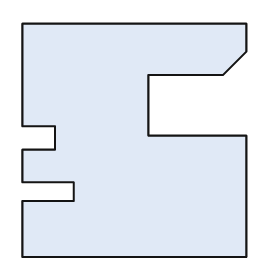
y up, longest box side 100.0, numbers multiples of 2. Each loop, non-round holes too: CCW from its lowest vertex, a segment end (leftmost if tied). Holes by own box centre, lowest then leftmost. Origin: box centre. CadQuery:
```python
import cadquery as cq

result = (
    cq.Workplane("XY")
    .moveTo(-48.0, -50.0)
    .lineTo(48.0, -50.0)
    .lineTo(48.0, 2.0)
    .lineTo(6.0, 2.0)
    .lineTo(6.0, 28.0)
    .lineTo(38.0, 28.0)
    .lineTo(48.0, 38.0)
    .lineTo(48.0, 50.0)
    .lineTo(-48.0, 50.0)
    .lineTo(-48.0, 6.0)
    .lineTo(-34.0, 6.0)
    .lineTo(-34.0, -4.0)
    .lineTo(-48.0, -4.0)
    .lineTo(-48.0, -18.0)
    .lineTo(-26.0, -18.0)
    .lineTo(-26.0, -26.0)
    .lineTo(-48.0, -26.0)
    .close()
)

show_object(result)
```